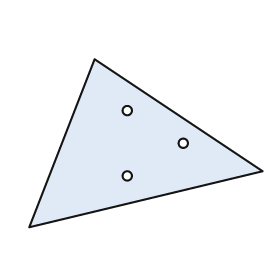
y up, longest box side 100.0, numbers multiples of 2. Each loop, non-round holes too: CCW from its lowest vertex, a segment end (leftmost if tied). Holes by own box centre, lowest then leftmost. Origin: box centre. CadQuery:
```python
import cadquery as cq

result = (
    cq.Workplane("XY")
    .moveTo(-50.0, -36.0)
    .lineTo(50.0, -12.0)
    .lineTo(-22.0, 36.0)
    .close()
    .moveTo(-8.0, -14.0)
    .circle(2.0)
    .moveTo(16.0, 0.0)
    .circle(2.0)
    .moveTo(-8.0, 14.0)
    .circle(2.0)
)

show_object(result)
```